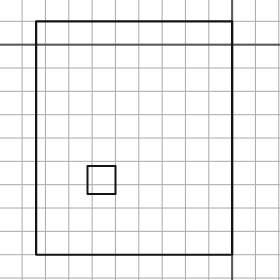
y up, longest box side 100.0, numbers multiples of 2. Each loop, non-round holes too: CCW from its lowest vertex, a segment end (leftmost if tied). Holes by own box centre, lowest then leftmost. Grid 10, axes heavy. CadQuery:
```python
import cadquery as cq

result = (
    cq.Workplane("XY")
    .moveTo(-84.0, -90.0)
    .lineTo(0.0, -90.0)
    .lineTo(0.0, 10.0)
    .lineTo(-84.0, 10.0)
    .close()
    .moveTo(-62.0, -64.0)
    .lineTo(-50.0, -64.0)
    .lineTo(-50.0, -52.0)
    .lineTo(-62.0, -52.0)
    .close()
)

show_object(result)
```